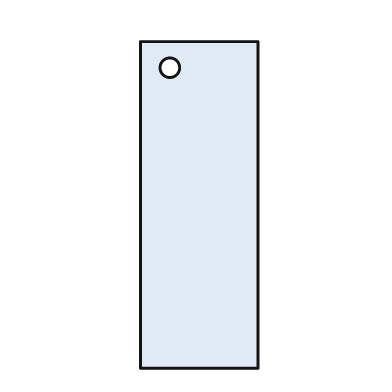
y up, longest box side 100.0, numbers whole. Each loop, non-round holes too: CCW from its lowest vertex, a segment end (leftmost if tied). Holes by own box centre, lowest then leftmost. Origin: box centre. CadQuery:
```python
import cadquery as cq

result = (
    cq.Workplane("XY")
    .moveTo(-18.0, -50.0)
    .lineTo(18.0, -50.0)
    .lineTo(18.0, 50.0)
    .lineTo(-18.0, 50.0)
    .close()
    .moveTo(-9.0, 42.0)
    .circle(3.0)
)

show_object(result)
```